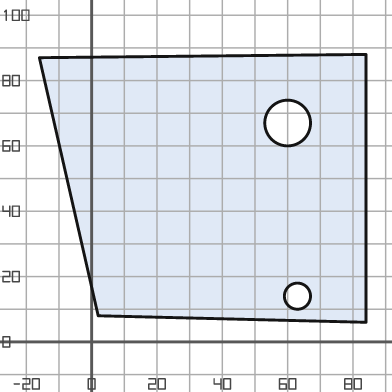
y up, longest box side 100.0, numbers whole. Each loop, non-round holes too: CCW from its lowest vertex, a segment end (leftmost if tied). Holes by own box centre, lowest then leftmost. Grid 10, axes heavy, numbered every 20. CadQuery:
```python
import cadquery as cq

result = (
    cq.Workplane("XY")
    .moveTo(84.0, 6.0)
    .lineTo(84.0, 88.0)
    .lineTo(-16.0, 87.0)
    .lineTo(2.0, 8.0)
    .close()
    .moveTo(63.0, 14.0)
    .circle(4.0)
    .moveTo(60.0, 67.0)
    .circle(7.0)
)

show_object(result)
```